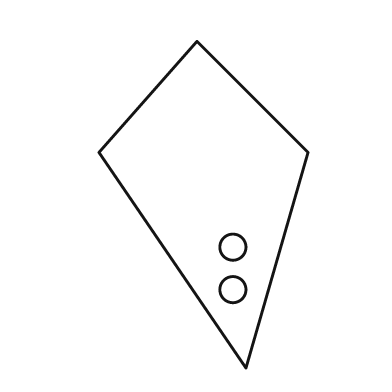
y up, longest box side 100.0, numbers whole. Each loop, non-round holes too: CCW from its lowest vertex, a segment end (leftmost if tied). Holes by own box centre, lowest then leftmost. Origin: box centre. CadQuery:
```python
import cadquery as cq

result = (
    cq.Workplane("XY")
    .moveTo(13.0, -50.0)
    .lineTo(32.0, 16.0)
    .lineTo(-2.0, 50.0)
    .lineTo(-32.0, 16.0)
    .close()
    .moveTo(9.0, -26.0)
    .circle(4.0)
    .moveTo(9.0, -13.0)
    .circle(4.0)
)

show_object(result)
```